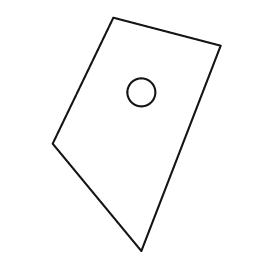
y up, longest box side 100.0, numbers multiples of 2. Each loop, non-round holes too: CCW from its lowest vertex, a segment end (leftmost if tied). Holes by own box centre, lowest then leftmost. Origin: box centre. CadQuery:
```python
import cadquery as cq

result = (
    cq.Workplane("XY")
    .moveTo(2.0, -50.0)
    .lineTo(36.0, 38.0)
    .lineTo(-10.0, 50.0)
    .lineTo(-36.0, -4.0)
    .close()
    .moveTo(2.0, 18.0)
    .circle(6.0)
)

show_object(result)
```